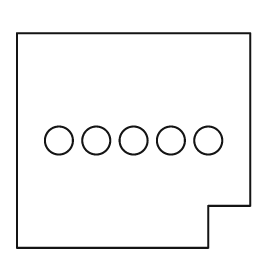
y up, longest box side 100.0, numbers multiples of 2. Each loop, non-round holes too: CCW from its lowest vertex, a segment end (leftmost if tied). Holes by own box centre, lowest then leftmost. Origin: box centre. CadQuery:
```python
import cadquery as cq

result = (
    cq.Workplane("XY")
    .moveTo(-50.0, -46.0)
    .lineTo(32.0, -46.0)
    .lineTo(32.0, -28.0)
    .lineTo(50.0, -28.0)
    .lineTo(50.0, 46.0)
    .lineTo(-50.0, 46.0)
    .close()
    .moveTo(-32.0, 0.0)
    .circle(6.0)
    .moveTo(-16.0, 0.0)
    .circle(6.0)
    .moveTo(0.0, 0.0)
    .circle(6.0)
    .moveTo(16.0, 0.0)
    .circle(6.0)
    .moveTo(32.0, 0.0)
    .circle(6.0)
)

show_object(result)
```